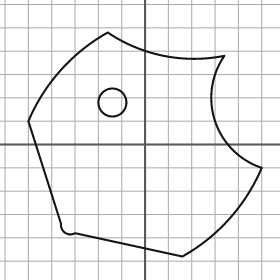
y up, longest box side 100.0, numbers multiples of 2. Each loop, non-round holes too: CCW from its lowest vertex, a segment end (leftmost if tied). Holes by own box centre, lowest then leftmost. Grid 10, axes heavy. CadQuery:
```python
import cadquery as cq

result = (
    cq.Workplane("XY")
    .moveTo(16.0, -48.0)
    .threePointArc((36.0, -32.0), (50.0, -10.0))
    .threePointArc((30.0, 10.0), (34.0, 38.0))
    .threePointArc((8.0, 38.0), (-16.0, 48.0))
    .threePointArc((-36.0, 32.0), (-50.0, 10.0))
    .lineTo(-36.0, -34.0)
    .threePointArc((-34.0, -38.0), (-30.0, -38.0))
    .close()
    .moveTo(-14.0, 18.0)
    .circle(6.0)
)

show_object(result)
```